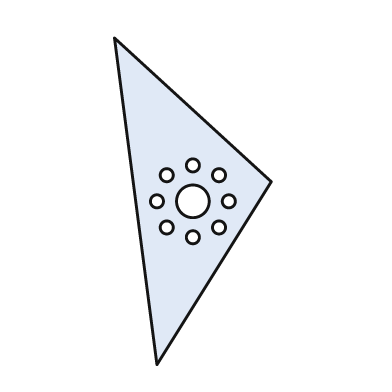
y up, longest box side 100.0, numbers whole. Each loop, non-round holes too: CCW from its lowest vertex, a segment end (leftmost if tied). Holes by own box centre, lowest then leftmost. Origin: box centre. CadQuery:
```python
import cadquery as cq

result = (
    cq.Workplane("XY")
    .moveTo(-11.0, -50.0)
    .lineTo(24.0, 6.0)
    .lineTo(-24.0, 50.0)
    .close()
    .moveTo(0.0, -11.0)
    .circle(2.0)
    .moveTo(-8.0, -8.0)
    .circle(2.0)
    .moveTo(8.0, -8.0)
    .circle(2.0)
    .moveTo(-11.0, 0.0)
    .circle(2.0)
    .moveTo(0.0, 0.0)
    .circle(5.0)
    .moveTo(11.0, 0.0)
    .circle(2.0)
    .moveTo(-8.0, 8.0)
    .circle(2.0)
    .moveTo(8.0, 8.0)
    .circle(2.0)
    .moveTo(0.0, 11.0)
    .circle(2.0)
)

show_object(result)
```